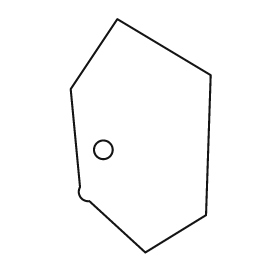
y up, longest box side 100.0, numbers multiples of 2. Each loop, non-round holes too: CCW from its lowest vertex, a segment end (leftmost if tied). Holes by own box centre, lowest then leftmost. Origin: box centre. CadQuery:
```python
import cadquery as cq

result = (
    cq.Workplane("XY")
    .moveTo(2.0, -50.0)
    .lineTo(28.0, -34.0)
    .lineTo(30.0, 26.0)
    .lineTo(-10.0, 50.0)
    .lineTo(-30.0, 20.0)
    .lineTo(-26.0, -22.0)
    .threePointArc((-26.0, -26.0), (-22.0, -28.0))
    .close()
    .moveTo(-16.0, -6.0)
    .circle(4.0)
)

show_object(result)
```